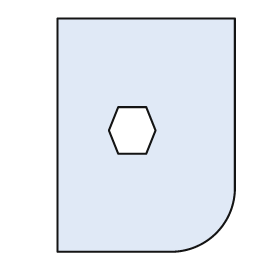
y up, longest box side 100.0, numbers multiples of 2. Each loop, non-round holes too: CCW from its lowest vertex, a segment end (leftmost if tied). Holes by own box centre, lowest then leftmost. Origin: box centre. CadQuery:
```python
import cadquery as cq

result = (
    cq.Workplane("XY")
    .moveTo(-38.0, -50.0)
    .lineTo(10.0, -50.0)
    .threePointArc((30.0, -42.0), (38.0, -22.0))
    .lineTo(38.0, 50.0)
    .lineTo(-38.0, 50.0)
    .close()
    .moveTo(-12.0, -8.0)
    .lineTo(0.0, -8.0)
    .lineTo(4.0, 2.0)
    .lineTo(0.0, 12.0)
    .lineTo(-12.0, 12.0)
    .lineTo(-16.0, 2.0)
    .close()
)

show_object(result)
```